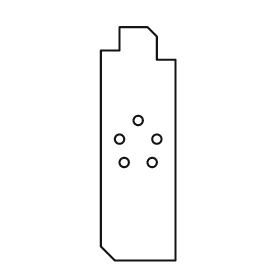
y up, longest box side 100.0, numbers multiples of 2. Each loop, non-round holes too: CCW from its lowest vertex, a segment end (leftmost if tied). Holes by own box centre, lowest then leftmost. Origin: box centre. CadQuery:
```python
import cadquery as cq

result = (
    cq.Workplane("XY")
    .moveTo(-10.0, -50.0)
    .lineTo(16.0, -50.0)
    .lineTo(16.0, 36.0)
    .lineTo(8.0, 36.0)
    .lineTo(8.0, 46.0)
    .lineTo(4.0, 50.0)
    .lineTo(-8.0, 50.0)
    .lineTo(-8.0, 40.0)
    .lineTo(-16.0, 40.0)
    .lineTo(-16.0, -44.0)
    .close()
    .moveTo(-6.0, -8.0)
    .circle(2.0)
    .moveTo(6.0, -8.0)
    .circle(2.0)
    .moveTo(-8.0, 2.0)
    .circle(2.0)
    .moveTo(8.0, 2.0)
    .circle(2.0)
    .moveTo(0.0, 10.0)
    .circle(2.0)
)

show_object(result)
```